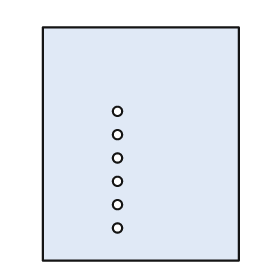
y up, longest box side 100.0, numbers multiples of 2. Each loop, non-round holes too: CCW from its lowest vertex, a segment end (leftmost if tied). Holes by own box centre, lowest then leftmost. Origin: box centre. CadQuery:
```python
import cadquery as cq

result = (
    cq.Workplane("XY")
    .moveTo(-42.0, -50.0)
    .lineTo(42.0, -50.0)
    .lineTo(42.0, 50.0)
    .lineTo(-42.0, 50.0)
    .close()
    .moveTo(-10.0, -36.0)
    .circle(2.0)
    .moveTo(-10.0, -26.0)
    .circle(2.0)
    .moveTo(-10.0, -16.0)
    .circle(2.0)
    .moveTo(-10.0, -6.0)
    .circle(2.0)
    .moveTo(-10.0, 4.0)
    .circle(2.0)
    .moveTo(-10.0, 14.0)
    .circle(2.0)
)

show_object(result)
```